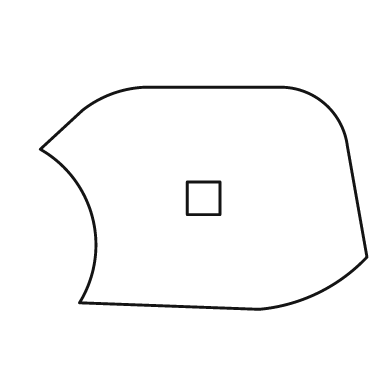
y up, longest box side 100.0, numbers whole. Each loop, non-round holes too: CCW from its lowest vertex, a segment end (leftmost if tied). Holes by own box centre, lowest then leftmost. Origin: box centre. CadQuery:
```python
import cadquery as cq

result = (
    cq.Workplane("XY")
    .moveTo(17.0, -34.0)
    .threePointArc((35.0, -29.0), (50.0, -18.0))
    .lineTo(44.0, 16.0)
    .threePointArc((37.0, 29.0), (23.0, 34.0))
    .lineTo(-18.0, 34.0)
    .threePointArc((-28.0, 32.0), (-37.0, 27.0))
    .lineTo(-50.0, 15.0)
    .threePointArc((-34.0, -6.0), (-38.0, -32.0))
    .close()
    .moveTo(-5.0, -5.0)
    .lineTo(5.0, -5.0)
    .lineTo(5.0, 5.0)
    .lineTo(-5.0, 5.0)
    .close()
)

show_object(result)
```